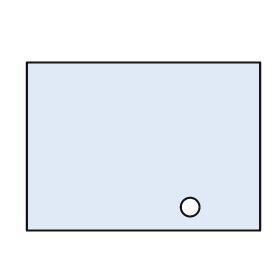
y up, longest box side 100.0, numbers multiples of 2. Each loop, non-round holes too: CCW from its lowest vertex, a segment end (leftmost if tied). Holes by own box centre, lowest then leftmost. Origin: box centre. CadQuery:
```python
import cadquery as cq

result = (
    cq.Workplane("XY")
    .moveTo(-50.0, -36.0)
    .lineTo(50.0, -36.0)
    .lineTo(50.0, 36.0)
    .lineTo(-50.0, 36.0)
    .close()
    .moveTo(20.0, -26.0)
    .circle(4.0)
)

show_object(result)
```